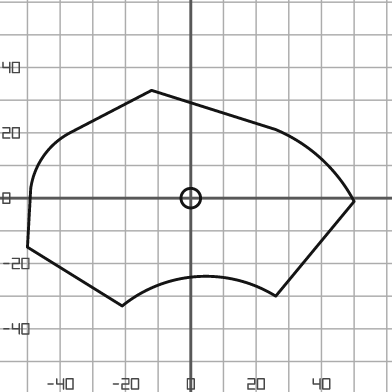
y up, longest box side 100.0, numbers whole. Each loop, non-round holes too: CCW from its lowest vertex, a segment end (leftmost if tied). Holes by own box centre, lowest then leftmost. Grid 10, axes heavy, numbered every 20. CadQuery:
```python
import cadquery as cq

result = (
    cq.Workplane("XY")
    .moveTo(-21.0, -33.0)
    .threePointArc((2.0, -24.0), (26.0, -30.0))
    .lineTo(50.0, -1.0)
    .threePointArc((40.0, 12.0), (26.0, 21.0))
    .lineTo(-12.0, 33.0)
    .lineTo(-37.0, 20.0)
    .threePointArc((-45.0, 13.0), (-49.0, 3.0))
    .lineTo(-50.0, -15.0)
    .close()
    .moveTo(0.0, 0.0)
    .circle(3.0)
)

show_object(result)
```